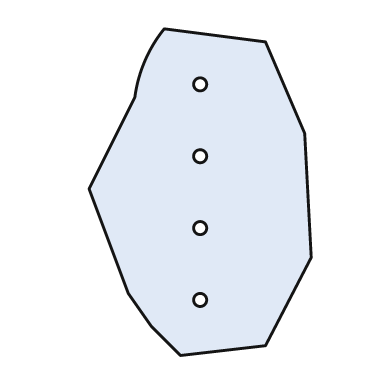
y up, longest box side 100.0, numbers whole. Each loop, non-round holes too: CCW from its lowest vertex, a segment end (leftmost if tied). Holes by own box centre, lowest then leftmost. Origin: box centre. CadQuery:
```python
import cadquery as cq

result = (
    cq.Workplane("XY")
    .moveTo(-6.0, -50.0)
    .lineTo(20.0, -47.0)
    .lineTo(34.0, -20.0)
    .lineTo(32.0, 18.0)
    .lineTo(20.0, 46.0)
    .lineTo(-11.0, 50.0)
    .threePointArc((-17.0, 40.0), (-20.0, 29.0))
    .lineTo(-34.0, 1.0)
    .lineTo(-22.0, -31.0)
    .lineTo(-15.0, -41.0)
    .close()
    .moveTo(0.0, -33.0)
    .circle(2.0)
    .moveTo(0.0, -11.0)
    .circle(2.0)
    .moveTo(0.0, 11.0)
    .circle(2.0)
    .moveTo(0.0, 33.0)
    .circle(2.0)
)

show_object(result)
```